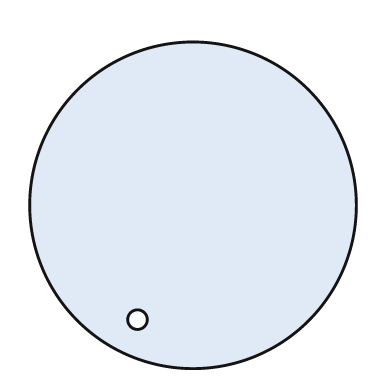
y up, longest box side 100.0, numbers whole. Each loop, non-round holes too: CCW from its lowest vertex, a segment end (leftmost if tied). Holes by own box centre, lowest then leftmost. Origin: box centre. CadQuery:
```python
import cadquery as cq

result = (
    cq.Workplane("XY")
    .moveTo(0.0, 0.0)
    .circle(50.0)
    .moveTo(-17.0, -35.0)
    .circle(3.0)
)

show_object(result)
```